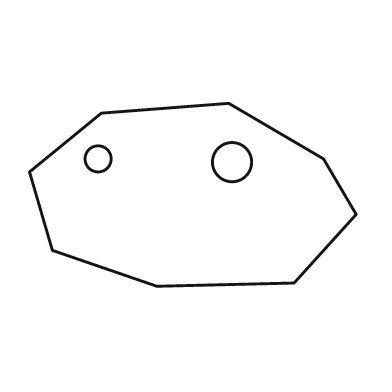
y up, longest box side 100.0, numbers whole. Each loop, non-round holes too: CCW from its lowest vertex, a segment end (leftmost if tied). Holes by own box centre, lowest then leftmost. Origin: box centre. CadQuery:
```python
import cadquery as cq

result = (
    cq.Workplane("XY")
    .moveTo(-11.0, -28.0)
    .lineTo(31.0, -27.0)
    .lineTo(50.0, -6.0)
    .lineTo(40.0, 11.0)
    .lineTo(11.0, 28.0)
    .lineTo(-28.0, 25.0)
    .lineTo(-50.0, 7.0)
    .lineTo(-43.0, -17.0)
    .close()
    .moveTo(12.0, 10.0)
    .circle(6.0)
    .moveTo(-29.0, 11.0)
    .circle(4.0)
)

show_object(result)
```